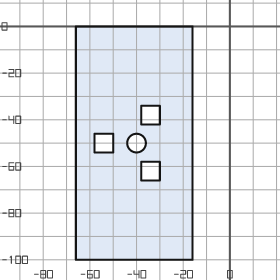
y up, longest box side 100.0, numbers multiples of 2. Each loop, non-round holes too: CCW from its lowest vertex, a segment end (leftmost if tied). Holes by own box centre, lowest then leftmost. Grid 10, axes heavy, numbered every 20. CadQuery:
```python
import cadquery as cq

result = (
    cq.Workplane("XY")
    .moveTo(-66.0, -100.0)
    .lineTo(-16.0, -100.0)
    .lineTo(-16.0, 0.0)
    .lineTo(-66.0, 0.0)
    .close()
    .moveTo(-38.0, -66.0)
    .lineTo(-30.0, -66.0)
    .lineTo(-30.0, -58.0)
    .lineTo(-38.0, -58.0)
    .close()
    .moveTo(-58.0, -54.0)
    .lineTo(-50.0, -54.0)
    .lineTo(-50.0, -46.0)
    .lineTo(-58.0, -46.0)
    .close()
    .moveTo(-40.0, -50.0)
    .circle(4.0)
    .moveTo(-38.0, -42.0)
    .lineTo(-30.0, -42.0)
    .lineTo(-30.0, -34.0)
    .lineTo(-38.0, -34.0)
    .close()
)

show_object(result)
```